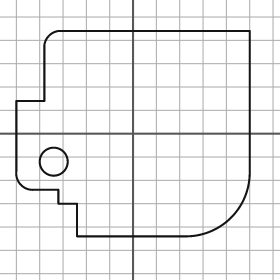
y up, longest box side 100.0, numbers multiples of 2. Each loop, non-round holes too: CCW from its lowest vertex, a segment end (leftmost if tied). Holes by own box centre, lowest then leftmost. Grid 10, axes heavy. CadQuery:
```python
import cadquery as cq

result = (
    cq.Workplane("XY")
    .moveTo(-24.0, -44.0)
    .lineTo(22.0, -44.0)
    .threePointArc((42.0, -36.0), (50.0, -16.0))
    .lineTo(50.0, 44.0)
    .lineTo(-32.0, 44.0)
    .threePointArc((-36.0, 42.0), (-38.0, 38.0))
    .lineTo(-38.0, 14.0)
    .lineTo(-50.0, 14.0)
    .lineTo(-50.0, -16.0)
    .threePointArc((-48.0, -22.0), (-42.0, -24.0))
    .lineTo(-32.0, -24.0)
    .lineTo(-32.0, -30.0)
    .lineTo(-24.0, -30.0)
    .close()
    .moveTo(-34.0, -12.0)
    .circle(6.0)
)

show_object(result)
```